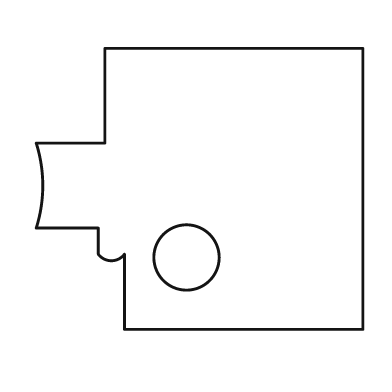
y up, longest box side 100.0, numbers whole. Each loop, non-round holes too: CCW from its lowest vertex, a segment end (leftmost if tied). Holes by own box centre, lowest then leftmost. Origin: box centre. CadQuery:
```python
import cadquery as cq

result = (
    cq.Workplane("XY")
    .moveTo(-23.0, -43.0)
    .lineTo(50.0, -43.0)
    .lineTo(50.0, 43.0)
    .lineTo(-29.0, 43.0)
    .lineTo(-29.0, 14.0)
    .lineTo(-50.0, 14.0)
    .threePointArc((-48.0, 1.0), (-50.0, -12.0))
    .lineTo(-31.0, -12.0)
    .lineTo(-31.0, -20.0)
    .threePointArc((-27.0, -22.0), (-23.0, -20.0))
    .close()
    .moveTo(-4.0, -21.0)
    .circle(10.0)
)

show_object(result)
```